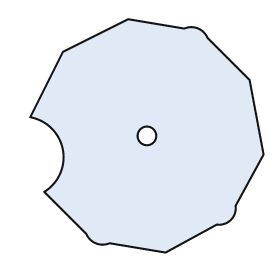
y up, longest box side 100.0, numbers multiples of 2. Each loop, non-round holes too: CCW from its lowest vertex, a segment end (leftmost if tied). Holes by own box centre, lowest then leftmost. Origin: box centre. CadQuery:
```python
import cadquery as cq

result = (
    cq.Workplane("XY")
    .moveTo(8.0, -50.0)
    .lineTo(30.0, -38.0)
    .threePointArc((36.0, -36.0), (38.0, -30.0))
    .lineTo(50.0, -8.0)
    .lineTo(44.0, 24.0)
    .lineTo(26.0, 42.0)
    .threePointArc((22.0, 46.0), (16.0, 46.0))
    .lineTo(-8.0, 50.0)
    .lineTo(-36.0, 36.0)
    .lineTo(-50.0, 8.0)
    .threePointArc((-36.0, -6.0), (-44.0, -24.0))
    .lineTo(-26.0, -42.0)
    .threePointArc((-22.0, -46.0), (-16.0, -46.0))
    .close()
    .moveTo(0.0, 0.0)
    .circle(4.0)
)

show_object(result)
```